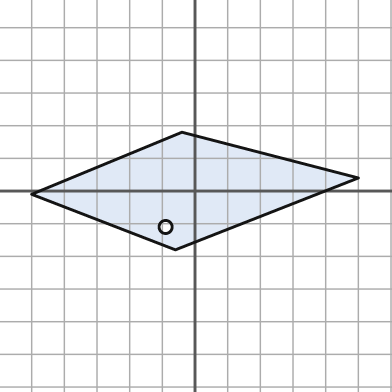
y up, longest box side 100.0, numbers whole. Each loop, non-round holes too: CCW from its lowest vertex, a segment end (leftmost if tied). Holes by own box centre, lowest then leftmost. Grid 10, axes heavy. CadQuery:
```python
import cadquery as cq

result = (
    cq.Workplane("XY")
    .moveTo(-6.0, -18.0)
    .lineTo(50.0, 4.0)
    .lineTo(-4.0, 18.0)
    .lineTo(-50.0, -1.0)
    .close()
    .moveTo(-9.0, -11.0)
    .circle(2.0)
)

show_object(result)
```